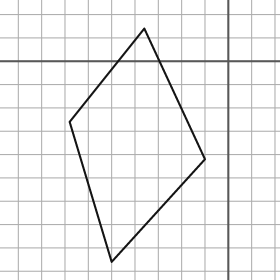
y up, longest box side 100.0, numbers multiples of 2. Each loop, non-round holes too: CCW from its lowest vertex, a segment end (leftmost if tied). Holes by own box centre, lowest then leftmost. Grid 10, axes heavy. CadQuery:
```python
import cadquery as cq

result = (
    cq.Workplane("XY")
    .moveTo(-50.0, -86.0)
    .lineTo(-10.0, -42.0)
    .lineTo(-36.0, 14.0)
    .lineTo(-68.0, -26.0)
    .close()
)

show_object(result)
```